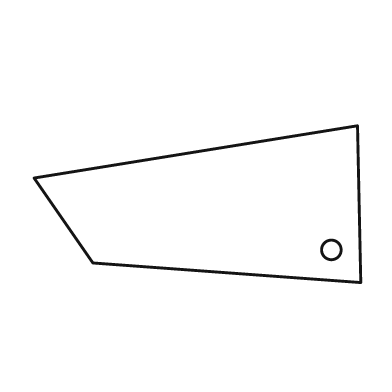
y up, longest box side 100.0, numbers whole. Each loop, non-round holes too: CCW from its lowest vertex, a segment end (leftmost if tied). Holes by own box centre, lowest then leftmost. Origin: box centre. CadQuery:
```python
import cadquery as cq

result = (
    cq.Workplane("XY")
    .moveTo(50.0, -24.0)
    .lineTo(49.0, 24.0)
    .lineTo(-50.0, 8.0)
    .lineTo(-32.0, -18.0)
    .close()
    .moveTo(41.0, -14.0)
    .circle(3.0)
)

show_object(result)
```